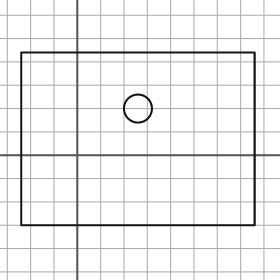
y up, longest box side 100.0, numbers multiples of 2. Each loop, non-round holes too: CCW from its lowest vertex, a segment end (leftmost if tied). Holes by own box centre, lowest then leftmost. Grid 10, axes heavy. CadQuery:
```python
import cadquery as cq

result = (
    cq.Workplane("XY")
    .moveTo(-24.0, -30.0)
    .lineTo(76.0, -30.0)
    .lineTo(76.0, 44.0)
    .lineTo(-24.0, 44.0)
    .close()
    .moveTo(26.0, 20.0)
    .circle(6.0)
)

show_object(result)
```